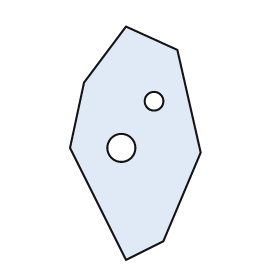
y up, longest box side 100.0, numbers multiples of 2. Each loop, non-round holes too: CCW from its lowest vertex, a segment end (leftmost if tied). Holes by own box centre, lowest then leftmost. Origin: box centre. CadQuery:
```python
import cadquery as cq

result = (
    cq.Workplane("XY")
    .moveTo(-4.0, -50.0)
    .lineTo(12.0, -42.0)
    .lineTo(28.0, -4.0)
    .lineTo(18.0, 40.0)
    .lineTo(-4.0, 50.0)
    .lineTo(-22.0, 26.0)
    .lineTo(-28.0, -2.0)
    .close()
    .moveTo(-6.0, -2.0)
    .circle(6.0)
    .moveTo(8.0, 18.0)
    .circle(4.0)
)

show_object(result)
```